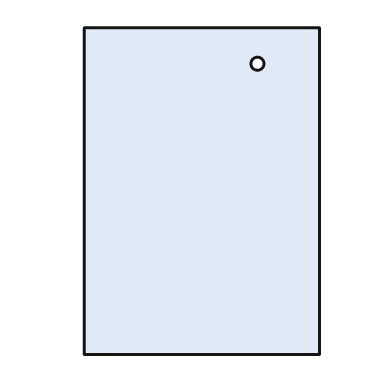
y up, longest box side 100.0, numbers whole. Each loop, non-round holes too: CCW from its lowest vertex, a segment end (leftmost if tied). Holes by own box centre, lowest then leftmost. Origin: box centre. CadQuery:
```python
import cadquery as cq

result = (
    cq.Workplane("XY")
    .moveTo(-36.0, -50.0)
    .lineTo(36.0, -50.0)
    .lineTo(36.0, 50.0)
    .lineTo(-36.0, 50.0)
    .close()
    .moveTo(17.0, 39.0)
    .circle(2.0)
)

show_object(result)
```